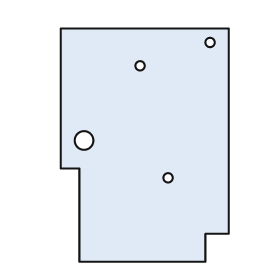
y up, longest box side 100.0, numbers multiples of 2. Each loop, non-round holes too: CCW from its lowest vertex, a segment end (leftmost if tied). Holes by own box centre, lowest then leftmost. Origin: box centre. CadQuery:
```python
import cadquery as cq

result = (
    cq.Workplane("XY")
    .moveTo(-28.0, -50.0)
    .lineTo(26.0, -50.0)
    .lineTo(26.0, -38.0)
    .lineTo(36.0, -38.0)
    .lineTo(36.0, 50.0)
    .lineTo(-36.0, 50.0)
    .lineTo(-36.0, -10.0)
    .lineTo(-28.0, -10.0)
    .close()
    .moveTo(10.0, -14.0)
    .circle(2.0)
    .moveTo(-26.0, 2.0)
    .circle(4.0)
    .moveTo(-2.0, 34.0)
    .circle(2.0)
    .moveTo(28.0, 44.0)
    .circle(2.0)
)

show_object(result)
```